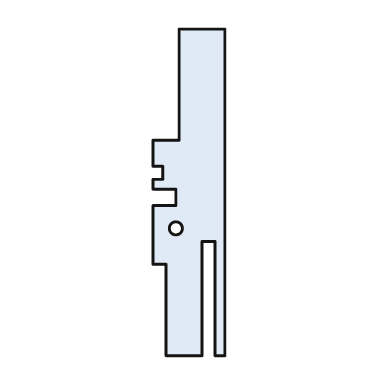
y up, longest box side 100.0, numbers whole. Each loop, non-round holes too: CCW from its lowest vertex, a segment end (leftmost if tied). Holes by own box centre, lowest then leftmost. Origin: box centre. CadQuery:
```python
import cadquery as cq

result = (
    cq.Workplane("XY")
    .moveTo(-7.0, -50.0)
    .lineTo(4.0, -50.0)
    .lineTo(4.0, -15.0)
    .lineTo(8.0, -15.0)
    .lineTo(8.0, -50.0)
    .lineTo(11.0, -50.0)
    .lineTo(11.0, 50.0)
    .lineTo(-3.0, 50.0)
    .lineTo(-3.0, 16.0)
    .lineTo(-11.0, 16.0)
    .lineTo(-11.0, 8.0)
    .lineTo(-8.0, 8.0)
    .lineTo(-8.0, 4.0)
    .lineTo(-11.0, 4.0)
    .lineTo(-11.0, 1.0)
    .lineTo(-4.0, 1.0)
    .lineTo(-4.0, -4.0)
    .lineTo(-11.0, -4.0)
    .lineTo(-11.0, -22.0)
    .lineTo(-7.0, -22.0)
    .close()
    .moveTo(-4.0, -11.0)
    .circle(2.0)
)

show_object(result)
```